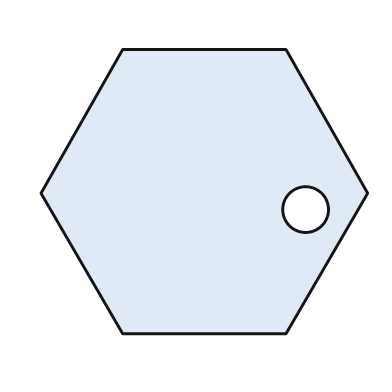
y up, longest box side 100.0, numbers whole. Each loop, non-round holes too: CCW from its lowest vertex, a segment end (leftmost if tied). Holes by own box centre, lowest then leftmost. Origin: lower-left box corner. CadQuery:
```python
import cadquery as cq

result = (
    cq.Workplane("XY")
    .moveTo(25.0, 0.0)
    .lineTo(75.0, 0.0)
    .lineTo(100.0, 43.0)
    .lineTo(75.0, 87.0)
    .lineTo(25.0, 87.0)
    .lineTo(0.0, 43.0)
    .close()
    .moveTo(81.0, 38.0)
    .circle(7.0)
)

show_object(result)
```